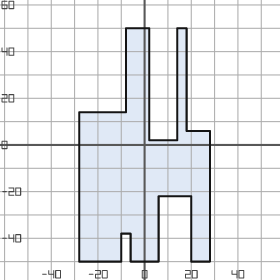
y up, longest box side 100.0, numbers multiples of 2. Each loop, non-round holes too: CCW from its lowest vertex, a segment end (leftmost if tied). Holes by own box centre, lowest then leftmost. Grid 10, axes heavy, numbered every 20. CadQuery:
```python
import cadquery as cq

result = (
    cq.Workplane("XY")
    .moveTo(-28.0, -50.0)
    .lineTo(-10.0, -50.0)
    .lineTo(-10.0, -38.0)
    .lineTo(-6.0, -38.0)
    .lineTo(-6.0, -50.0)
    .lineTo(6.0, -50.0)
    .lineTo(6.0, -22.0)
    .lineTo(20.0, -22.0)
    .lineTo(20.0, -50.0)
    .lineTo(28.0, -50.0)
    .lineTo(28.0, 6.0)
    .lineTo(18.0, 6.0)
    .lineTo(18.0, 50.0)
    .lineTo(14.0, 50.0)
    .lineTo(14.0, 2.0)
    .lineTo(2.0, 2.0)
    .lineTo(2.0, 50.0)
    .lineTo(-8.0, 50.0)
    .lineTo(-8.0, 14.0)
    .lineTo(-28.0, 14.0)
    .close()
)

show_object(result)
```